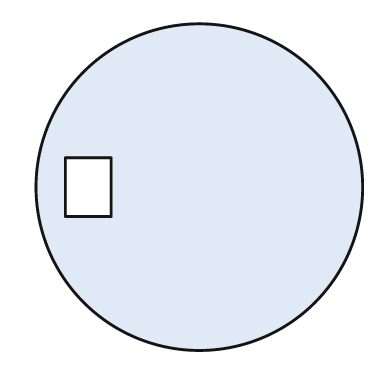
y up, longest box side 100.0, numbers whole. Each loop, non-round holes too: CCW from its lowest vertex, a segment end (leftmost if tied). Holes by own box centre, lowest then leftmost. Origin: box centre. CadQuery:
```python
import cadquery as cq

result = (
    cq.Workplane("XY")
    .moveTo(0.0, 0.0)
    .circle(50.0)
    .moveTo(-41.0, -9.0)
    .lineTo(-27.0, -9.0)
    .lineTo(-27.0, 9.0)
    .lineTo(-41.0, 9.0)
    .close()
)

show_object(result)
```